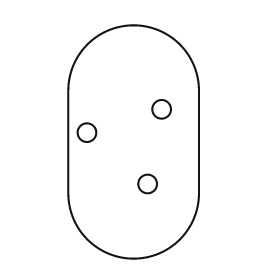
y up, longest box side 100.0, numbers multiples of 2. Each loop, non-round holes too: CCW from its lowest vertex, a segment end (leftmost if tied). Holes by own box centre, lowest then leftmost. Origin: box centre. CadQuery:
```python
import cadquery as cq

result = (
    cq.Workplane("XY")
    .moveTo(-28.0, -22.0)
    .threePointArc((0.0, -50.0), (28.0, -22.0))
    .lineTo(28.0, 22.0)
    .threePointArc((0.0, 50.0), (-28.0, 22.0))
    .close()
    .moveTo(6.0, -18.0)
    .circle(4.0)
    .moveTo(-20.0, 4.0)
    .circle(4.0)
    .moveTo(12.0, 14.0)
    .circle(4.0)
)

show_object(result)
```